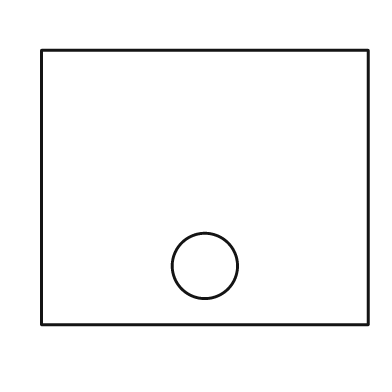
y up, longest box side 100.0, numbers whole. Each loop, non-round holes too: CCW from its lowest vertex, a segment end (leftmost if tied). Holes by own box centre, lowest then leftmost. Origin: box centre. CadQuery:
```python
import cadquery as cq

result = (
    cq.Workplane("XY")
    .moveTo(-50.0, -42.0)
    .lineTo(50.0, -42.0)
    .lineTo(50.0, 42.0)
    .lineTo(-50.0, 42.0)
    .close()
    .moveTo(0.0, -24.0)
    .circle(10.0)
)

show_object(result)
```